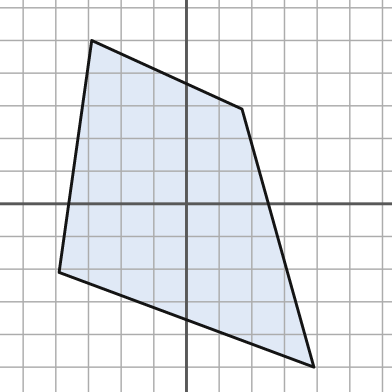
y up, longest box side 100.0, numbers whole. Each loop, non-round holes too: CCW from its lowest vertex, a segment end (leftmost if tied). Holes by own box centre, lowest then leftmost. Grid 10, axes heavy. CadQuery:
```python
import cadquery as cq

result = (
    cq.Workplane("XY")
    .moveTo(39.0, -50.0)
    .lineTo(17.0, 29.0)
    .lineTo(-29.0, 50.0)
    .lineTo(-39.0, -21.0)
    .close()
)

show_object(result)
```